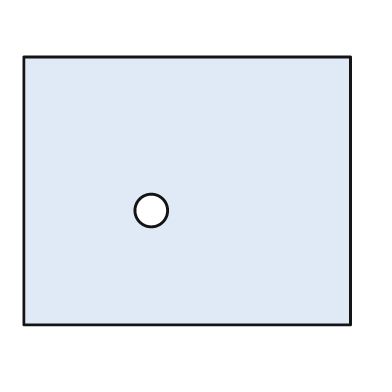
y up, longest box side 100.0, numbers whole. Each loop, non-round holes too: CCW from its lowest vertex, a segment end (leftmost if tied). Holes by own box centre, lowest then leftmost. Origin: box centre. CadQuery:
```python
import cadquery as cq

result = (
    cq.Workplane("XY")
    .moveTo(-50.0, -41.0)
    .lineTo(50.0, -41.0)
    .lineTo(50.0, 41.0)
    .lineTo(-50.0, 41.0)
    .close()
    .moveTo(-11.0, -6.0)
    .circle(5.0)
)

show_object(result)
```